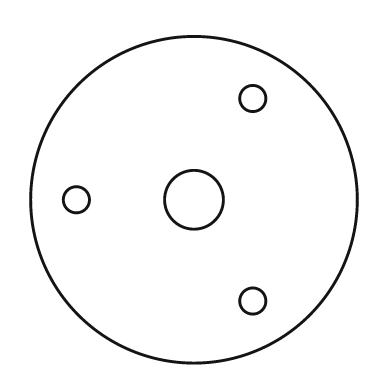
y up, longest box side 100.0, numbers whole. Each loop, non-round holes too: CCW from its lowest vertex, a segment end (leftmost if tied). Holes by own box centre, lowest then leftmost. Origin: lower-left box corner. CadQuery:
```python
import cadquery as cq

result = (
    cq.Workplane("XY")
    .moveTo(50.0, 50.0)
    .circle(50.0)
    .moveTo(68.0, 19.0)
    .circle(4.0)
    .moveTo(14.0, 50.0)
    .circle(4.0)
    .moveTo(50.0, 50.0)
    .circle(9.0)
    .moveTo(68.0, 81.0)
    .circle(4.0)
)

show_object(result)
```